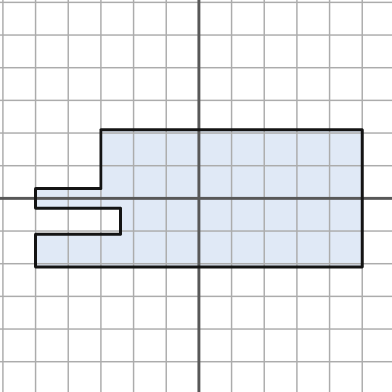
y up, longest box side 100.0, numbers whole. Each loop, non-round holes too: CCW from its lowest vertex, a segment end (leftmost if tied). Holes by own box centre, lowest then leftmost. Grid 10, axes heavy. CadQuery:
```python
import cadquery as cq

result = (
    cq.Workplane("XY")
    .moveTo(-50.0, -21.0)
    .lineTo(50.0, -21.0)
    .lineTo(50.0, 21.0)
    .lineTo(-30.0, 21.0)
    .lineTo(-30.0, 3.0)
    .lineTo(-50.0, 3.0)
    .lineTo(-50.0, -3.0)
    .lineTo(-24.0, -3.0)
    .lineTo(-24.0, -11.0)
    .lineTo(-50.0, -11.0)
    .close()
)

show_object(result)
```